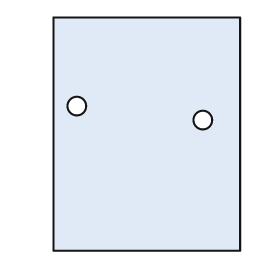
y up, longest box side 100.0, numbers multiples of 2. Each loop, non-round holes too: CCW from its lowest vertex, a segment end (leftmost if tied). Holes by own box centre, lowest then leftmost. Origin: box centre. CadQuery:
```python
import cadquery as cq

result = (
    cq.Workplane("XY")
    .moveTo(-40.0, -50.0)
    .lineTo(40.0, -50.0)
    .lineTo(40.0, 50.0)
    .lineTo(-40.0, 50.0)
    .close()
    .moveTo(24.0, 6.0)
    .circle(4.0)
    .moveTo(-30.0, 12.0)
    .circle(4.0)
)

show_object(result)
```